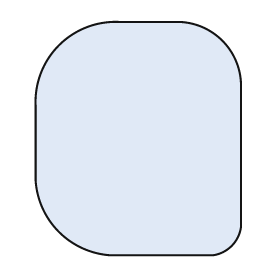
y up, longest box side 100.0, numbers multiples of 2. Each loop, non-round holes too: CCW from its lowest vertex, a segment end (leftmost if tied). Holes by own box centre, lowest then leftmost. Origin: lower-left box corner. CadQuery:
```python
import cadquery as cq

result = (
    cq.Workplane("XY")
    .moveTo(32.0, 0.0)
    .lineTo(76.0, 0.0)
    .threePointArc((84.0, 4.0), (88.0, 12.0))
    .lineTo(88.0, 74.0)
    .threePointArc((80.0, 92.0), (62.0, 100.0))
    .lineTo(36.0, 100.0)
    .threePointArc((10.0, 90.0), (0.0, 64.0))
    .lineTo(0.0, 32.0)
    .threePointArc((10.0, 10.0), (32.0, 0.0))
    .close()
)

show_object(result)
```